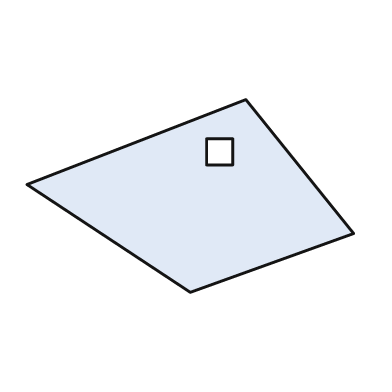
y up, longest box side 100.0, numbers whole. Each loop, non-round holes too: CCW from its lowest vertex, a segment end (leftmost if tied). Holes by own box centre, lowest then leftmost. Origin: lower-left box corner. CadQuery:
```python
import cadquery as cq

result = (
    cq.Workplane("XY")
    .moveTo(50.0, 0.0)
    .lineTo(100.0, 18.0)
    .lineTo(67.0, 59.0)
    .lineTo(0.0, 33.0)
    .close()
    .moveTo(55.0, 39.0)
    .lineTo(63.0, 39.0)
    .lineTo(63.0, 47.0)
    .lineTo(55.0, 47.0)
    .close()
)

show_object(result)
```